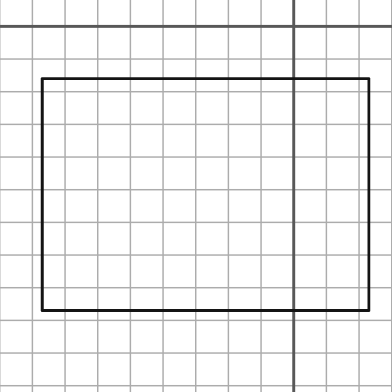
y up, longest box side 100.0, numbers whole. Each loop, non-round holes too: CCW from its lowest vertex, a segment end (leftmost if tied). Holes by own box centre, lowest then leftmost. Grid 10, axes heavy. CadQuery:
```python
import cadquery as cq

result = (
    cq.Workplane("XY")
    .moveTo(-77.0, -87.0)
    .lineTo(23.0, -87.0)
    .lineTo(23.0, -16.0)
    .lineTo(-77.0, -16.0)
    .close()
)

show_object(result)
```